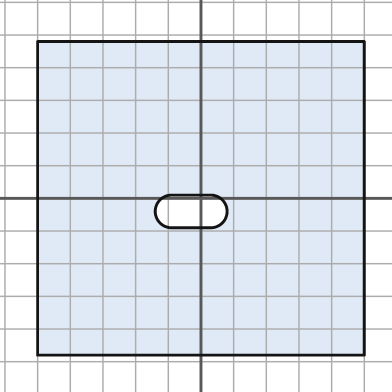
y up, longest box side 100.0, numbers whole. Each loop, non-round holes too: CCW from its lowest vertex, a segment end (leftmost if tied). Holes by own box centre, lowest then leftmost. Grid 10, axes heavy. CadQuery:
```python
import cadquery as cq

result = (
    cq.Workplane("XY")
    .moveTo(-50.0, -48.0)
    .lineTo(50.0, -48.0)
    .lineTo(50.0, 48.0)
    .lineTo(-50.0, 48.0)
    .close()
    .moveTo(-9.0, -9.0)
    .lineTo(3.0, -9.0)
    .threePointArc((8.0, -4.0), (3.0, 1.0))
    .lineTo(-9.0, 1.0)
    .threePointArc((-14.0, -4.0), (-9.0, -9.0))
    .close()
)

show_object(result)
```